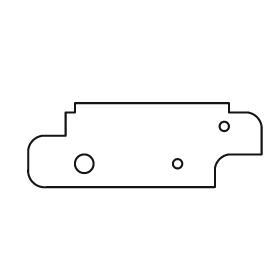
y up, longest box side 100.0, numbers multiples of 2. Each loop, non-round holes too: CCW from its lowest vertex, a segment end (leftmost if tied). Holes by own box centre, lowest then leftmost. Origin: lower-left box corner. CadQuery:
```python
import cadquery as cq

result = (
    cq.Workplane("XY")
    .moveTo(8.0, 0.0)
    .lineTo(80.0, 0.0)
    .lineTo(80.0, 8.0)
    .threePointArc((82.0, 12.0), (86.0, 14.0))
    .lineTo(100.0, 14.0)
    .lineTo(100.0, 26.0)
    .threePointArc((98.0, 30.0), (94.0, 32.0))
    .lineTo(86.0, 32.0)
    .lineTo(86.0, 36.0)
    .lineTo(20.0, 36.0)
    .lineTo(20.0, 32.0)
    .lineTo(16.0, 32.0)
    .lineTo(16.0, 22.0)
    .lineTo(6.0, 22.0)
    .threePointArc((2.0, 20.0), (0.0, 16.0))
    .lineTo(0.0, 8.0)
    .threePointArc((2.0, 2.0), (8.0, 0.0))
    .close()
    .moveTo(24.0, 10.0)
    .circle(4.0)
    .moveTo(64.0, 10.0)
    .circle(2.0)
    .moveTo(84.0, 26.0)
    .circle(2.0)
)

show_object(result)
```